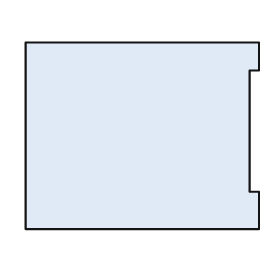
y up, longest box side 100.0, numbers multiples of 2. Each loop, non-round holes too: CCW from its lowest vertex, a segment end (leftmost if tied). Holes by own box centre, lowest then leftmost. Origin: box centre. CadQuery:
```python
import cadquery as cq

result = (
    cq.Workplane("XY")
    .moveTo(-50.0, -40.0)
    .lineTo(50.0, -40.0)
    .lineTo(50.0, -24.0)
    .lineTo(46.0, -24.0)
    .lineTo(46.0, 28.0)
    .lineTo(50.0, 28.0)
    .lineTo(50.0, 40.0)
    .lineTo(-50.0, 40.0)
    .close()
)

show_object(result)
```